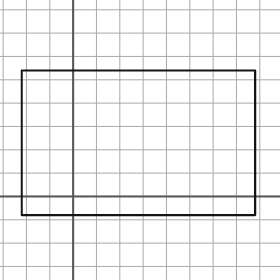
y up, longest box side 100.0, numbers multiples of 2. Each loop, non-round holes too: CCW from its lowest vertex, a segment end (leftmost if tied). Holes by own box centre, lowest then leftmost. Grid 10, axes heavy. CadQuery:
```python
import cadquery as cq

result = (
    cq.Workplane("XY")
    .moveTo(-22.0, -8.0)
    .lineTo(78.0, -8.0)
    .lineTo(78.0, 54.0)
    .lineTo(-22.0, 54.0)
    .close()
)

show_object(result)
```